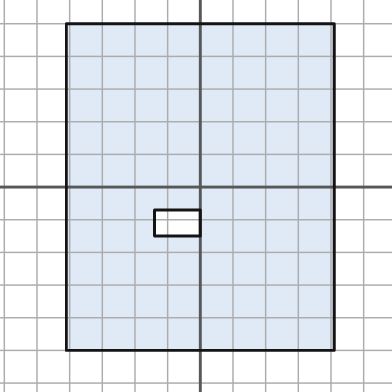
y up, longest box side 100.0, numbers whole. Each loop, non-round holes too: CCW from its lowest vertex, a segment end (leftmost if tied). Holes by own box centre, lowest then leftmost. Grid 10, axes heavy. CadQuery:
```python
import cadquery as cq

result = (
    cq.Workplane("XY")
    .moveTo(-41.0, -50.0)
    .lineTo(41.0, -50.0)
    .lineTo(41.0, 50.0)
    .lineTo(-41.0, 50.0)
    .close()
    .moveTo(-14.0, -15.0)
    .lineTo(0.0, -15.0)
    .lineTo(0.0, -7.0)
    .lineTo(-14.0, -7.0)
    .close()
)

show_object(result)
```